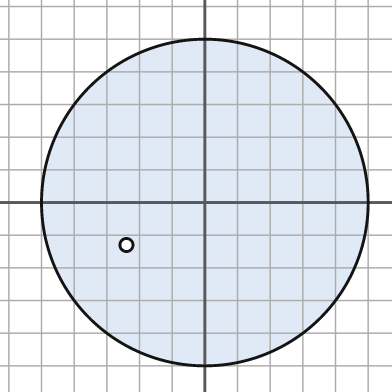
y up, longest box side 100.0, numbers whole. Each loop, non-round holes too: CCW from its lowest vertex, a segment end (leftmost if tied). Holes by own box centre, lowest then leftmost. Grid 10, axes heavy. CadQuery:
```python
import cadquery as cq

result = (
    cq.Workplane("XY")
    .moveTo(0.0, 0.0)
    .circle(50.0)
    .moveTo(-24.0, -13.0)
    .circle(2.0)
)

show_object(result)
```